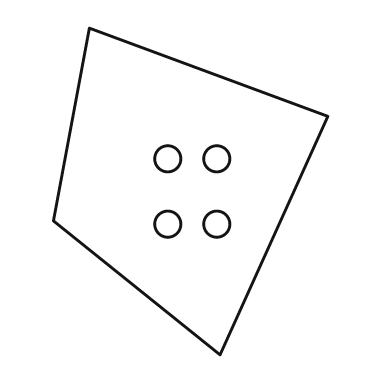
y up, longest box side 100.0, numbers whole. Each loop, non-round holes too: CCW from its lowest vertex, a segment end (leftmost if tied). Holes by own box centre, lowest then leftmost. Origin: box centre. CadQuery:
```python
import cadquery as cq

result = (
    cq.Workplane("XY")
    .moveTo(9.0, -50.0)
    .lineTo(42.0, 23.0)
    .lineTo(-31.0, 50.0)
    .lineTo(-42.0, -9.0)
    .close()
    .moveTo(-7.0, -10.0)
    .circle(4.0)
    .moveTo(8.0, -10.0)
    .circle(4.0)
    .moveTo(-7.0, 10.0)
    .circle(4.0)
    .moveTo(8.0, 10.0)
    .circle(4.0)
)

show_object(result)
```